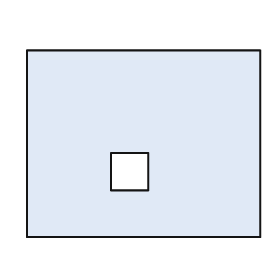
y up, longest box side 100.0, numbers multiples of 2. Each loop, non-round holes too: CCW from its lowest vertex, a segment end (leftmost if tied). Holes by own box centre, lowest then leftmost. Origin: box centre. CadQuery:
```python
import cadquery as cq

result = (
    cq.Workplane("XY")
    .moveTo(-50.0, -40.0)
    .lineTo(50.0, -40.0)
    .lineTo(50.0, 40.0)
    .lineTo(-50.0, 40.0)
    .close()
    .moveTo(-14.0, -20.0)
    .lineTo(2.0, -20.0)
    .lineTo(2.0, -4.0)
    .lineTo(-14.0, -4.0)
    .close()
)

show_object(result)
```